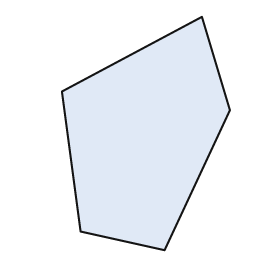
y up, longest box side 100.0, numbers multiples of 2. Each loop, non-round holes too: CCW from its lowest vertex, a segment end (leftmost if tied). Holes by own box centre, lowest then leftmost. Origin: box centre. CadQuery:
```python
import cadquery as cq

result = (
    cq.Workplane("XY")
    .moveTo(8.0, -50.0)
    .lineTo(36.0, 10.0)
    .lineTo(24.0, 50.0)
    .lineTo(-36.0, 18.0)
    .lineTo(-28.0, -42.0)
    .close()
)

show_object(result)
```